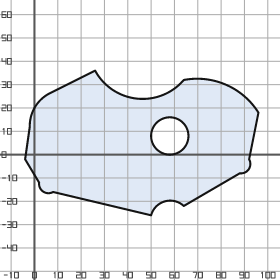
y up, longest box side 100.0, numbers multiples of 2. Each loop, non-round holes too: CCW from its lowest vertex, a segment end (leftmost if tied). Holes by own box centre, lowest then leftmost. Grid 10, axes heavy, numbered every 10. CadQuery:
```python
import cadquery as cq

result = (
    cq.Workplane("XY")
    .moveTo(50.0, -26.0)
    .threePointArc((56.0, -20.0), (64.0, -22.0))
    .lineTo(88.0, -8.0)
    .threePointArc((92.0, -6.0), (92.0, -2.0))
    .lineTo(96.0, 18.0)
    .threePointArc((82.0, 30.0), (64.0, 32.0))
    .threePointArc((44.0, 24.0), (26.0, 36.0))
    .lineTo(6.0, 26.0)
    .threePointArc((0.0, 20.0), (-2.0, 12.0))
    .lineTo(-4.0, -2.0)
    .lineTo(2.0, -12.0)
    .threePointArc((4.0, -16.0), (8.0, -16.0))
    .close()
    .moveTo(58.0, 8.0)
    .circle(8.0)
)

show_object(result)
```